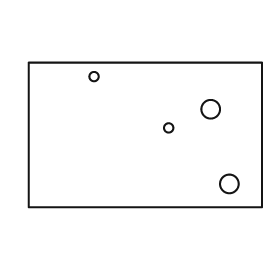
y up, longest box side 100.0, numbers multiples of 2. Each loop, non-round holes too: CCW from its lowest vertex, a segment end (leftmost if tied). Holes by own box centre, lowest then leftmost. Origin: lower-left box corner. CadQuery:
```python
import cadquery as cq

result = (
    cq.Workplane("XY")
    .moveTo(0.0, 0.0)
    .lineTo(100.0, 0.0)
    .lineTo(100.0, 62.0)
    .lineTo(0.0, 62.0)
    .close()
    .moveTo(86.0, 10.0)
    .circle(4.0)
    .moveTo(60.0, 34.0)
    .circle(2.0)
    .moveTo(78.0, 42.0)
    .circle(4.0)
    .moveTo(28.0, 56.0)
    .circle(2.0)
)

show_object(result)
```